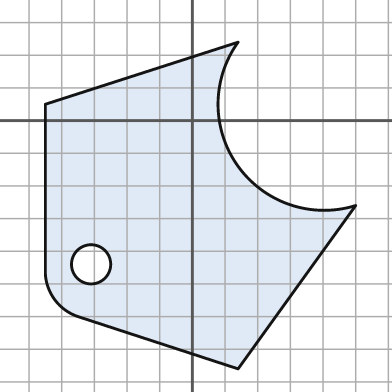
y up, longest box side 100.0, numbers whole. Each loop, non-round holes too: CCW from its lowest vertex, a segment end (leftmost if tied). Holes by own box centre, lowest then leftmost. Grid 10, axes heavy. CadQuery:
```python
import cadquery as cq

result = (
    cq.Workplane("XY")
    .moveTo(14.0, -76.0)
    .lineTo(50.0, -26.0)
    .threePointArc((14.0, -14.0), (14.0, 24.0))
    .lineTo(-45.0, 5.0)
    .lineTo(-45.0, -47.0)
    .threePointArc((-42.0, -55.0), (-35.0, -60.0))
    .close()
    .moveTo(-31.0, -44.0)
    .circle(6.0)
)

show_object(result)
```